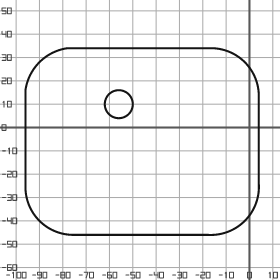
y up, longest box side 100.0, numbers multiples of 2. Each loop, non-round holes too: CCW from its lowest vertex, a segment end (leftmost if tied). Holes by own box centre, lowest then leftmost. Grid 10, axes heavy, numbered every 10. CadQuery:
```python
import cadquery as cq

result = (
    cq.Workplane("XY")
    .moveTo(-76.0, -46.0)
    .lineTo(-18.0, -46.0)
    .threePointArc((-2.0, -40.0), (4.0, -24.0))
    .lineTo(4.0, 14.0)
    .threePointArc((-2.0, 28.0), (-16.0, 34.0))
    .lineTo(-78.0, 34.0)
    .threePointArc((-90.0, 28.0), (-96.0, 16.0))
    .lineTo(-96.0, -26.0)
    .threePointArc((-90.0, -40.0), (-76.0, -46.0))
    .close()
    .moveTo(-56.0, 10.0)
    .circle(6.0)
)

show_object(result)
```